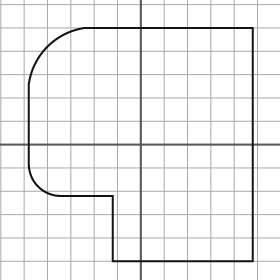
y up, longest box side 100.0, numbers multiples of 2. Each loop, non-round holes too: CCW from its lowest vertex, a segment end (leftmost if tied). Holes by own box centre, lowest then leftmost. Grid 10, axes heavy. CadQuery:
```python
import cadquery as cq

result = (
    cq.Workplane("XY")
    .moveTo(-12.0, -50.0)
    .lineTo(48.0, -50.0)
    .lineTo(48.0, 50.0)
    .lineTo(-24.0, 50.0)
    .threePointArc((-40.0, 42.0), (-48.0, 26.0))
    .lineTo(-48.0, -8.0)
    .threePointArc((-44.0, -18.0), (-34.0, -22.0))
    .lineTo(-12.0, -22.0)
    .close()
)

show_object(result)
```